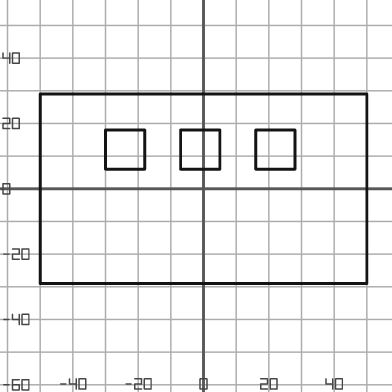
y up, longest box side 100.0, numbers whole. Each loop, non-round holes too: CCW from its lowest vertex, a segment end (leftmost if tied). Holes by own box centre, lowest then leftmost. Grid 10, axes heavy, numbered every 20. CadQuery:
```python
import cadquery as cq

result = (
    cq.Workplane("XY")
    .moveTo(-50.0, -29.0)
    .lineTo(50.0, -29.0)
    .lineTo(50.0, 29.0)
    .lineTo(-50.0, 29.0)
    .close()
    .moveTo(-30.0, 6.0)
    .lineTo(-18.0, 6.0)
    .lineTo(-18.0, 18.0)
    .lineTo(-30.0, 18.0)
    .close()
    .moveTo(-7.0, 6.0)
    .lineTo(5.0, 6.0)
    .lineTo(5.0, 18.0)
    .lineTo(-7.0, 18.0)
    .close()
    .moveTo(16.0, 6.0)
    .lineTo(28.0, 6.0)
    .lineTo(28.0, 18.0)
    .lineTo(16.0, 18.0)
    .close()
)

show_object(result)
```